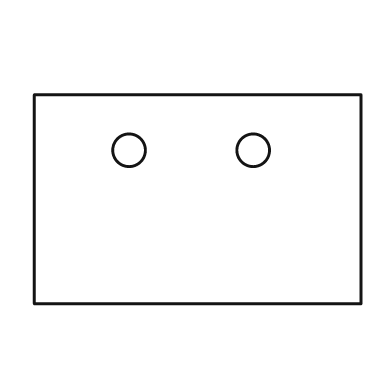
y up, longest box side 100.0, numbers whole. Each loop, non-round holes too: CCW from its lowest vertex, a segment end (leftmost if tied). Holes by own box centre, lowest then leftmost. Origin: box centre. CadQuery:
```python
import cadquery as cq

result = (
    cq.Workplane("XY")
    .moveTo(-50.0, -32.0)
    .lineTo(50.0, -32.0)
    .lineTo(50.0, 32.0)
    .lineTo(-50.0, 32.0)
    .close()
    .moveTo(-21.0, 15.0)
    .circle(5.0)
    .moveTo(17.0, 15.0)
    .circle(5.0)
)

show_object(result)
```